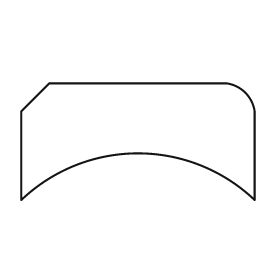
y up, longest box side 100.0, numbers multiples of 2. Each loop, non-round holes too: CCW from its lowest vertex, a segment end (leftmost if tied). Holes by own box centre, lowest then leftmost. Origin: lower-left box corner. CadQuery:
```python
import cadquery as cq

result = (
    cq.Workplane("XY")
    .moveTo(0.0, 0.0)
    .threePointArc((50.0, 20.0), (100.0, 0.0))
    .lineTo(100.0, 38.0)
    .threePointArc((96.0, 46.0), (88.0, 50.0))
    .lineTo(12.0, 50.0)
    .lineTo(0.0, 38.0)
    .close()
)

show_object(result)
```